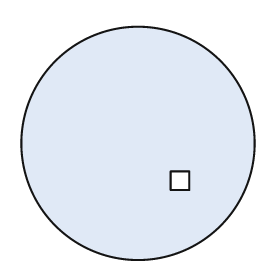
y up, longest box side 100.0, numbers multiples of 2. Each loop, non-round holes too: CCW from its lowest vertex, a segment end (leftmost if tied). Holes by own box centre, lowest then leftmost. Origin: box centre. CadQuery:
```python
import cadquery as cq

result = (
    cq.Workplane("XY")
    .moveTo(0.0, 0.0)
    .circle(50.0)
    .moveTo(14.0, -20.0)
    .lineTo(22.0, -20.0)
    .lineTo(22.0, -12.0)
    .lineTo(14.0, -12.0)
    .close()
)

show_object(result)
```